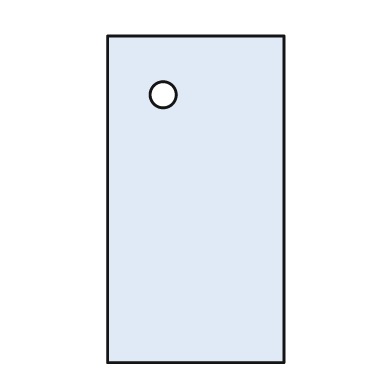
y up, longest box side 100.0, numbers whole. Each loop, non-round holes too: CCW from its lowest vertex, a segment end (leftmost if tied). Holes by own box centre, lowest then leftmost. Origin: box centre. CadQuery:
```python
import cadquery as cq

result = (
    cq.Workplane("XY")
    .moveTo(-27.0, -50.0)
    .lineTo(27.0, -50.0)
    .lineTo(27.0, 50.0)
    .lineTo(-27.0, 50.0)
    .close()
    .moveTo(-10.0, 32.0)
    .circle(4.0)
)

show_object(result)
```